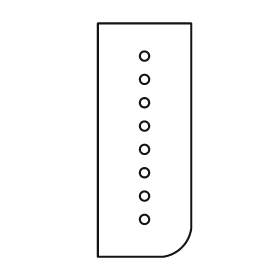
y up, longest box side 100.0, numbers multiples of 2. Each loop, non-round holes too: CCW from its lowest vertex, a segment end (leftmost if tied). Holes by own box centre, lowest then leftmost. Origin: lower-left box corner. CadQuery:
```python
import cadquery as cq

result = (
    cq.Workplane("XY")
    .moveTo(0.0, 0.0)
    .lineTo(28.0, 0.0)
    .threePointArc((36.0, 4.0), (40.0, 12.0))
    .lineTo(40.0, 100.0)
    .lineTo(0.0, 100.0)
    .close()
    .moveTo(20.0, 16.0)
    .circle(2.0)
    .moveTo(20.0, 26.0)
    .circle(2.0)
    .moveTo(20.0, 36.0)
    .circle(2.0)
    .moveTo(20.0, 46.0)
    .circle(2.0)
    .moveTo(20.0, 56.0)
    .circle(2.0)
    .moveTo(20.0, 66.0)
    .circle(2.0)
    .moveTo(20.0, 76.0)
    .circle(2.0)
    .moveTo(20.0, 86.0)
    .circle(2.0)
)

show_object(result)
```